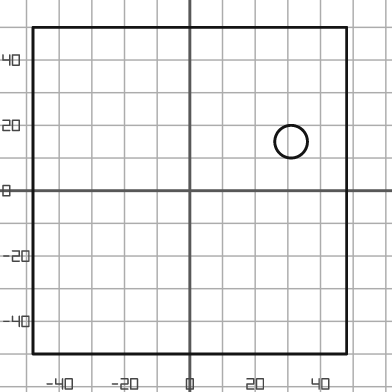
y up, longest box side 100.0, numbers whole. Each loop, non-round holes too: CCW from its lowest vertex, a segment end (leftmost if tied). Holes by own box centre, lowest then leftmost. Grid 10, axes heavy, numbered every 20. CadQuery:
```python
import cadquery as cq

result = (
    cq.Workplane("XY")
    .moveTo(-48.0, -50.0)
    .lineTo(48.0, -50.0)
    .lineTo(48.0, 50.0)
    .lineTo(-48.0, 50.0)
    .close()
    .moveTo(31.0, 15.0)
    .circle(5.0)
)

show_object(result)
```